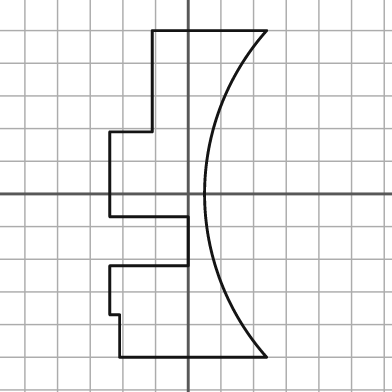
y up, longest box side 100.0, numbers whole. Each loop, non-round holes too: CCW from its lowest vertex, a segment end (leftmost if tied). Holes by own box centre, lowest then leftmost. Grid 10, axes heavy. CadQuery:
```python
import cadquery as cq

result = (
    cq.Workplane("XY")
    .moveTo(-21.0, -50.0)
    .lineTo(24.0, -50.0)
    .threePointArc((5.0, 0.0), (24.0, 50.0))
    .lineTo(-11.0, 50.0)
    .lineTo(-11.0, 19.0)
    .lineTo(-24.0, 19.0)
    .lineTo(-24.0, -7.0)
    .lineTo(0.0, -7.0)
    .lineTo(0.0, -22.0)
    .lineTo(-24.0, -22.0)
    .lineTo(-24.0, -37.0)
    .lineTo(-21.0, -37.0)
    .close()
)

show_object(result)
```